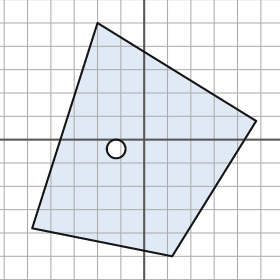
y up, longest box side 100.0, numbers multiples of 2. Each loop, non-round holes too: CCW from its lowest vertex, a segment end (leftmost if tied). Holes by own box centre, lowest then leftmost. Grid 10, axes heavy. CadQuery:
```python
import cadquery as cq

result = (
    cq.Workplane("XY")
    .moveTo(12.0, -50.0)
    .lineTo(48.0, 8.0)
    .lineTo(-20.0, 50.0)
    .lineTo(-48.0, -38.0)
    .close()
    .moveTo(-12.0, -4.0)
    .circle(4.0)
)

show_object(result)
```